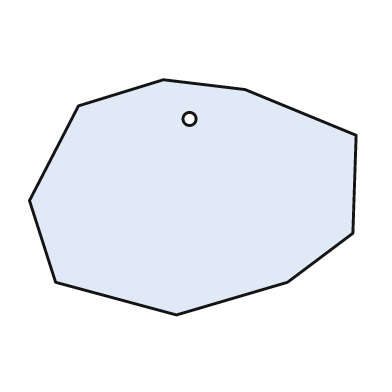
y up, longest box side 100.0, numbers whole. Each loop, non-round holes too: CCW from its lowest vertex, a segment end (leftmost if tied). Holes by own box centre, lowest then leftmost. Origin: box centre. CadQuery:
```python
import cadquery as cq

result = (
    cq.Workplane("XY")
    .moveTo(-5.0, -36.0)
    .lineTo(29.0, -26.0)
    .lineTo(49.0, -11.0)
    .lineTo(50.0, 19.0)
    .lineTo(16.0, 33.0)
    .lineTo(-9.0, 36.0)
    .lineTo(-35.0, 28.0)
    .lineTo(-50.0, -1.0)
    .lineTo(-42.0, -26.0)
    .close()
    .moveTo(-1.0, 24.0)
    .circle(2.0)
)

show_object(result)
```